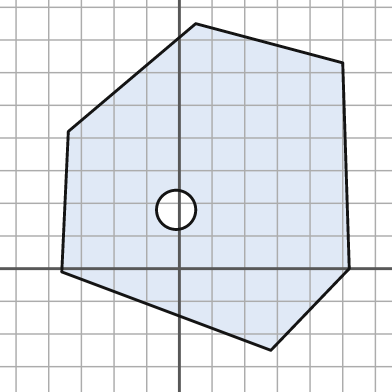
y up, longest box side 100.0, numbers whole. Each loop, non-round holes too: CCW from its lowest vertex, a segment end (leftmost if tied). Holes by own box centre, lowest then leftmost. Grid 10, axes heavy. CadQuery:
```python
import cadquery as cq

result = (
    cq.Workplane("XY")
    .moveTo(28.0, -25.0)
    .lineTo(52.0, 0.0)
    .lineTo(50.0, 63.0)
    .lineTo(5.0, 75.0)
    .lineTo(-34.0, 42.0)
    .lineTo(-36.0, -1.0)
    .close()
    .moveTo(-1.0, 18.0)
    .circle(6.0)
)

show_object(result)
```